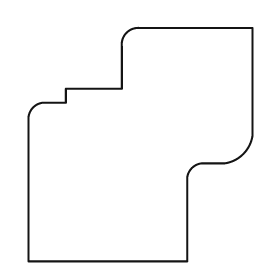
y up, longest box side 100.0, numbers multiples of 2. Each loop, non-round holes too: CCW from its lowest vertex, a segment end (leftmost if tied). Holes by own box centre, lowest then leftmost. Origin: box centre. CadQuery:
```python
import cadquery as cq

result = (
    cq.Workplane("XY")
    .moveTo(-48.0, -50.0)
    .lineTo(20.0, -50.0)
    .lineTo(20.0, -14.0)
    .threePointArc((22.0, -10.0), (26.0, -8.0))
    .lineTo(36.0, -8.0)
    .threePointArc((44.0, -4.0), (48.0, 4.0))
    .lineTo(48.0, 50.0)
    .lineTo(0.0, 50.0)
    .threePointArc((-6.0, 48.0), (-8.0, 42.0))
    .lineTo(-8.0, 24.0)
    .lineTo(-32.0, 24.0)
    .lineTo(-32.0, 18.0)
    .lineTo(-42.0, 18.0)
    .threePointArc((-46.0, 16.0), (-48.0, 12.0))
    .close()
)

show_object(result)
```